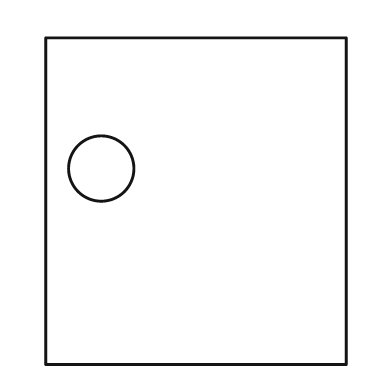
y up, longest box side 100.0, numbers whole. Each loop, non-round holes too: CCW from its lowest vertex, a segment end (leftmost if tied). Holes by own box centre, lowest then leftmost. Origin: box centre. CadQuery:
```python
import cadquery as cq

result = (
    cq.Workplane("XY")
    .moveTo(-46.0, -50.0)
    .lineTo(46.0, -50.0)
    .lineTo(46.0, 50.0)
    .lineTo(-46.0, 50.0)
    .close()
    .moveTo(-29.0, 10.0)
    .circle(10.0)
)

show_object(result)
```